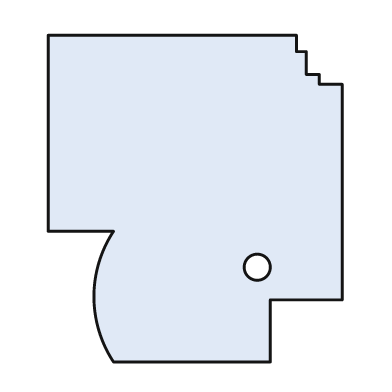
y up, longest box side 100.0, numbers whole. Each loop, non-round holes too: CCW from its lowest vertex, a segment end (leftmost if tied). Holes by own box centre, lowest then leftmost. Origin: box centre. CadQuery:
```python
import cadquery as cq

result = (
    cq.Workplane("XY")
    .moveTo(-25.0, -50.0)
    .lineTo(23.0, -50.0)
    .lineTo(23.0, -31.0)
    .lineTo(45.0, -31.0)
    .lineTo(45.0, 35.0)
    .lineTo(38.0, 35.0)
    .lineTo(38.0, 38.0)
    .lineTo(34.0, 38.0)
    .lineTo(34.0, 45.0)
    .lineTo(31.0, 45.0)
    .lineTo(31.0, 50.0)
    .lineTo(-45.0, 50.0)
    .lineTo(-45.0, -10.0)
    .lineTo(-25.0, -10.0)
    .threePointArc((-31.0, -30.0), (-25.0, -50.0))
    .close()
    .moveTo(19.0, -21.0)
    .circle(4.0)
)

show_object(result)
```